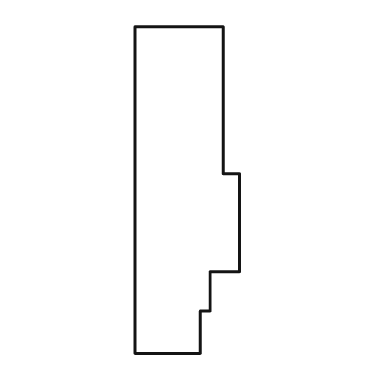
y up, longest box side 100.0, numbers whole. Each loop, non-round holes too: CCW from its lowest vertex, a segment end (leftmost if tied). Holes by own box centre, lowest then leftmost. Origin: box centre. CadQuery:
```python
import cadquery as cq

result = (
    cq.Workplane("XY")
    .moveTo(-16.0, -50.0)
    .lineTo(4.0, -50.0)
    .lineTo(4.0, -37.0)
    .lineTo(7.0, -37.0)
    .lineTo(7.0, -25.0)
    .lineTo(16.0, -25.0)
    .lineTo(16.0, 5.0)
    .lineTo(11.0, 5.0)
    .lineTo(11.0, 50.0)
    .lineTo(-16.0, 50.0)
    .close()
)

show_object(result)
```